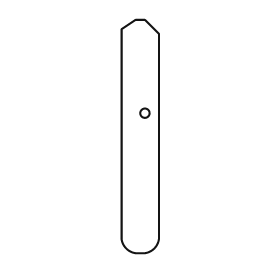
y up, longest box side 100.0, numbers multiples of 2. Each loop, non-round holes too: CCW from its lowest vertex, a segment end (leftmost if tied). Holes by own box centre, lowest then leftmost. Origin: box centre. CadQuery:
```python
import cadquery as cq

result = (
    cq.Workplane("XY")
    .moveTo(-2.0, -50.0)
    .lineTo(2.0, -50.0)
    .threePointArc((6.0, -48.0), (8.0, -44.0))
    .lineTo(8.0, 44.0)
    .lineTo(2.0, 50.0)
    .lineTo(-2.0, 50.0)
    .lineTo(-8.0, 46.0)
    .lineTo(-8.0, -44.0)
    .threePointArc((-6.0, -48.0), (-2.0, -50.0))
    .close()
    .moveTo(2.0, 10.0)
    .circle(2.0)
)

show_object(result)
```